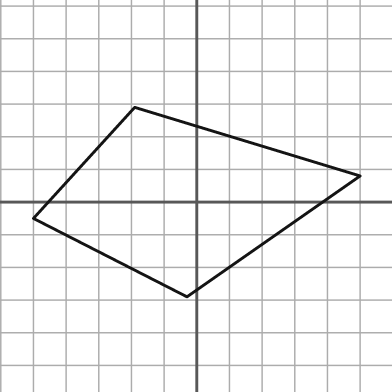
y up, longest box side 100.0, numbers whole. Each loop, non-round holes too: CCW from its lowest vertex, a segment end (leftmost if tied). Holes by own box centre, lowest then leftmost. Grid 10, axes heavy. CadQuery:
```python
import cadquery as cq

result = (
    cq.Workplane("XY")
    .moveTo(-3.0, -29.0)
    .lineTo(50.0, 8.0)
    .lineTo(-19.0, 29.0)
    .lineTo(-50.0, -5.0)
    .close()
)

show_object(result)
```